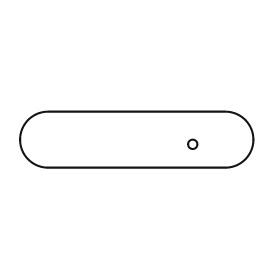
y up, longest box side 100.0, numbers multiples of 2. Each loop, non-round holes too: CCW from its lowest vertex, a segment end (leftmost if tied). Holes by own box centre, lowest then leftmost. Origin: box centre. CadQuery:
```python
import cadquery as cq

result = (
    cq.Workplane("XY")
    .moveTo(-38.0, -12.0)
    .lineTo(38.0, -12.0)
    .threePointArc((50.0, 0.0), (38.0, 12.0))
    .lineTo(-38.0, 12.0)
    .threePointArc((-50.0, 0.0), (-38.0, -12.0))
    .close()
    .moveTo(24.0, -2.0)
    .circle(2.0)
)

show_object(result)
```